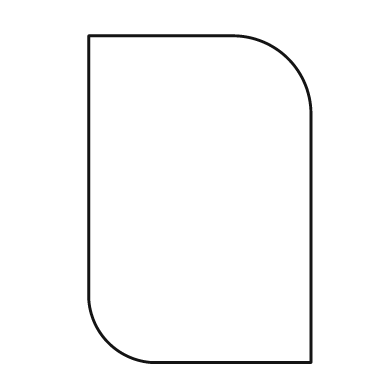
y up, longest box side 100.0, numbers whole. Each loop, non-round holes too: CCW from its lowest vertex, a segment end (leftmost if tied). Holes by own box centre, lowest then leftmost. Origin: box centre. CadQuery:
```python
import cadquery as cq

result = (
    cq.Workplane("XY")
    .moveTo(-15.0, -50.0)
    .lineTo(34.0, -50.0)
    .lineTo(34.0, 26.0)
    .threePointArc((27.0, 43.0), (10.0, 50.0))
    .lineTo(-34.0, 50.0)
    .lineTo(-34.0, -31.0)
    .threePointArc((-28.0, -44.0), (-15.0, -50.0))
    .close()
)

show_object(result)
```